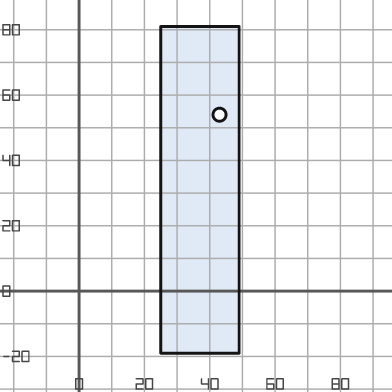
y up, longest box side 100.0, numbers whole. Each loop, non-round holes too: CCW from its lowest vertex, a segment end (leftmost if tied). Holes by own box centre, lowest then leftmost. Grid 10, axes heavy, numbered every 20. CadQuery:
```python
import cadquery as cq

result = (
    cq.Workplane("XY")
    .moveTo(25.0, -19.0)
    .lineTo(49.0, -19.0)
    .lineTo(49.0, 81.0)
    .lineTo(25.0, 81.0)
    .close()
    .moveTo(43.0, 54.0)
    .circle(2.0)
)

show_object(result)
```